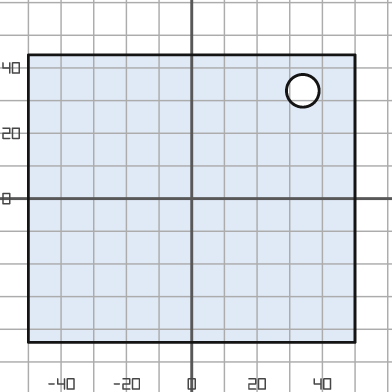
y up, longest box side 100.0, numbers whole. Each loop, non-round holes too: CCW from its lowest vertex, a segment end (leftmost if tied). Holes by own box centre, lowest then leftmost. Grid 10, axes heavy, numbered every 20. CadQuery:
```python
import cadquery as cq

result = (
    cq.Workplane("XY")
    .moveTo(-50.0, -44.0)
    .lineTo(50.0, -44.0)
    .lineTo(50.0, 44.0)
    .lineTo(-50.0, 44.0)
    .close()
    .moveTo(34.0, 33.0)
    .circle(5.0)
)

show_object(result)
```